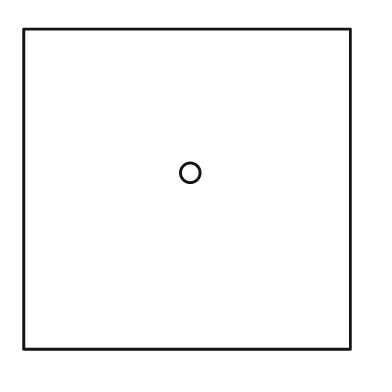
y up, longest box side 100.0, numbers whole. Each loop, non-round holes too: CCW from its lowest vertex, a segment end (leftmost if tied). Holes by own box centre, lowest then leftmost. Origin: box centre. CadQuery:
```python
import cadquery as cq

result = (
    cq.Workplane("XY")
    .moveTo(-50.0, -49.0)
    .lineTo(50.0, -49.0)
    .lineTo(50.0, 49.0)
    .lineTo(-50.0, 49.0)
    .close()
    .moveTo(1.0, 5.0)
    .circle(3.0)
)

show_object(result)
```